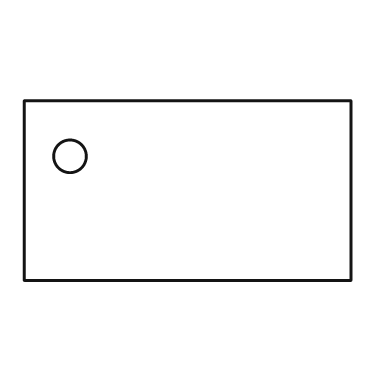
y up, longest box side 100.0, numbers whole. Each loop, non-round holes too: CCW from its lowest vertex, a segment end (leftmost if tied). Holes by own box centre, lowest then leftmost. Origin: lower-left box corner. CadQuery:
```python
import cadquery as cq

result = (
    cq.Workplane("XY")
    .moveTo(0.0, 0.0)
    .lineTo(100.0, 0.0)
    .lineTo(100.0, 55.0)
    .lineTo(0.0, 55.0)
    .close()
    .moveTo(14.0, 38.0)
    .circle(5.0)
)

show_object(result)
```